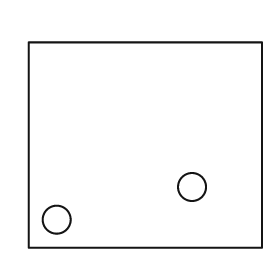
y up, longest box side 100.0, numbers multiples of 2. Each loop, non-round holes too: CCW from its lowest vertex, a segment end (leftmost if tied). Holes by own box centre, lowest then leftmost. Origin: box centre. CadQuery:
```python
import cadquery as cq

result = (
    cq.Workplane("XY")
    .moveTo(-50.0, -44.0)
    .lineTo(50.0, -44.0)
    .lineTo(50.0, 44.0)
    .lineTo(-50.0, 44.0)
    .close()
    .moveTo(-38.0, -32.0)
    .circle(6.0)
    .moveTo(20.0, -18.0)
    .circle(6.0)
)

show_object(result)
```